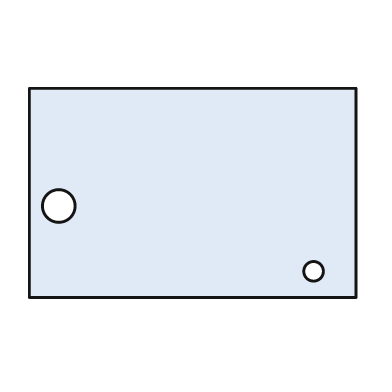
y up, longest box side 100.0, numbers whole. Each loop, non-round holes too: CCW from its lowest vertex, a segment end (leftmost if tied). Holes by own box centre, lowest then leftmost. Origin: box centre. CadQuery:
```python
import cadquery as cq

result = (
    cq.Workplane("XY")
    .moveTo(-50.0, -32.0)
    .lineTo(50.0, -32.0)
    .lineTo(50.0, 32.0)
    .lineTo(-50.0, 32.0)
    .close()
    .moveTo(37.0, -24.0)
    .circle(3.0)
    .moveTo(-41.0, -4.0)
    .circle(5.0)
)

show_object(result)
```